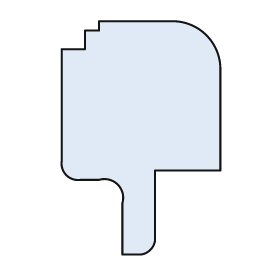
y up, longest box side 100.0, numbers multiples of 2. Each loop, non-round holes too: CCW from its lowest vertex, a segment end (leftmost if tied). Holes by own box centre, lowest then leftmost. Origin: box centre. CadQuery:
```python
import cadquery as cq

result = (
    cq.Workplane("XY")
    .moveTo(-8.0, -50.0)
    .lineTo(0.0, -50.0)
    .threePointArc((4.0, -48.0), (6.0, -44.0))
    .lineTo(6.0, -14.0)
    .lineTo(34.0, -14.0)
    .lineTo(34.0, 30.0)
    .threePointArc((28.0, 44.0), (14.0, 50.0))
    .lineTo(-18.0, 50.0)
    .lineTo(-18.0, 46.0)
    .lineTo(-24.0, 46.0)
    .lineTo(-24.0, 38.0)
    .lineTo(-34.0, 38.0)
    .lineTo(-34.0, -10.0)
    .threePointArc((-32.0, -16.0), (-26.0, -18.0))
    .lineTo(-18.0, -18.0)
    .threePointArc((-10.0, -20.0), (-8.0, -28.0))
    .close()
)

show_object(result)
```